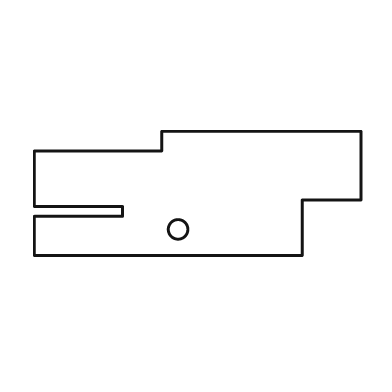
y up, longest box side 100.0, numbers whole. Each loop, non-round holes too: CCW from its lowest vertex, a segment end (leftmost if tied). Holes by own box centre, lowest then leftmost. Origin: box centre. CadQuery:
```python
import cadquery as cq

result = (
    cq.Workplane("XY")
    .moveTo(-50.0, -19.0)
    .lineTo(32.0, -19.0)
    .lineTo(32.0, -2.0)
    .lineTo(50.0, -2.0)
    .lineTo(50.0, 19.0)
    .lineTo(-11.0, 19.0)
    .lineTo(-11.0, 13.0)
    .lineTo(-50.0, 13.0)
    .lineTo(-50.0, -4.0)
    .lineTo(-23.0, -4.0)
    .lineTo(-23.0, -7.0)
    .lineTo(-50.0, -7.0)
    .close()
    .moveTo(-6.0, -11.0)
    .circle(3.0)
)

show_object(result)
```